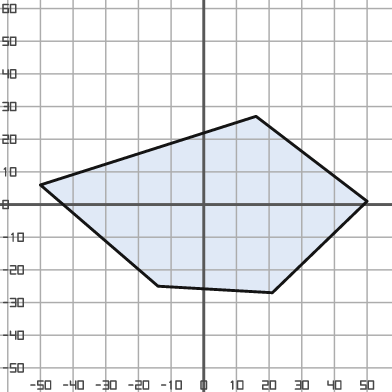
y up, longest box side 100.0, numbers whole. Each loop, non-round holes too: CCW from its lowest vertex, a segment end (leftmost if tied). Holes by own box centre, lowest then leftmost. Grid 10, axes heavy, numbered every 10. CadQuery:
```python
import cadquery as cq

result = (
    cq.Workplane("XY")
    .moveTo(21.0, -27.0)
    .lineTo(50.0, 1.0)
    .lineTo(16.0, 27.0)
    .lineTo(-50.0, 6.0)
    .lineTo(-14.0, -25.0)
    .close()
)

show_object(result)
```